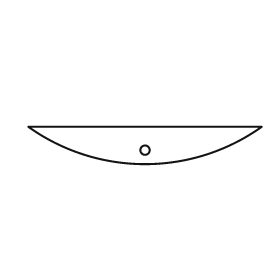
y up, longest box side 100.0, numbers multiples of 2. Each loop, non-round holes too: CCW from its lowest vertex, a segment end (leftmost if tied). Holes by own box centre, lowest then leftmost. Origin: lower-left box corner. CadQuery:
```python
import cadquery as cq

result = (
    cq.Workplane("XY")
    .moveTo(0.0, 16.0)
    .threePointArc((50.0, 0.0), (100.0, 16.0))
    .close()
    .moveTo(50.0, 6.0)
    .circle(2.0)
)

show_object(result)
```